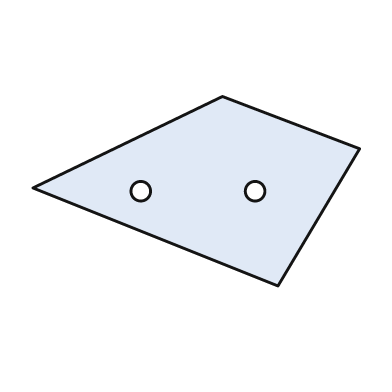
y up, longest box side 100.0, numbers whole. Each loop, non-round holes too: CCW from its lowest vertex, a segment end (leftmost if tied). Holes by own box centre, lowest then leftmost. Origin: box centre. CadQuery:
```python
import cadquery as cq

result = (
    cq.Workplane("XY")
    .moveTo(25.0, -29.0)
    .lineTo(50.0, 13.0)
    .lineTo(8.0, 29.0)
    .lineTo(-50.0, 1.0)
    .close()
    .moveTo(-17.0, 0.0)
    .circle(3.0)
    .moveTo(18.0, 0.0)
    .circle(3.0)
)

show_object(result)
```